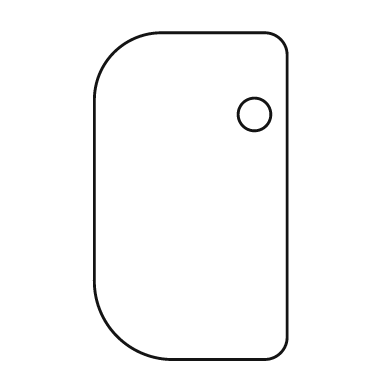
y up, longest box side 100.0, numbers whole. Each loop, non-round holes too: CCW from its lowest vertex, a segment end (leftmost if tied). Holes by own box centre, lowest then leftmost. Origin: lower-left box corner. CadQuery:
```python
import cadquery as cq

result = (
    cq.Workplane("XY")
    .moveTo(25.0, 0.0)
    .lineTo(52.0, 0.0)
    .threePointArc((57.0, 2.0), (59.0, 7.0))
    .lineTo(59.0, 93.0)
    .threePointArc((57.0, 98.0), (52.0, 100.0))
    .lineTo(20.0, 100.0)
    .threePointArc((6.0, 94.0), (0.0, 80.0))
    .lineTo(0.0, 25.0)
    .threePointArc((7.0, 7.0), (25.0, 0.0))
    .close()
    .moveTo(49.0, 75.0)
    .circle(5.0)
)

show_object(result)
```